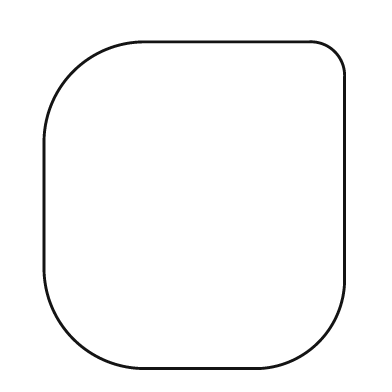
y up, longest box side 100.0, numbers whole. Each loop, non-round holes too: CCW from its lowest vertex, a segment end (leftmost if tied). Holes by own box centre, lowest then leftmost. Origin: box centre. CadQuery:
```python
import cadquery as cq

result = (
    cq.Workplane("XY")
    .moveTo(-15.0, -50.0)
    .lineTo(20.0, -50.0)
    .threePointArc((38.0, -42.0), (46.0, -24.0))
    .lineTo(46.0, 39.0)
    .threePointArc((43.0, 47.0), (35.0, 50.0))
    .lineTo(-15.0, 50.0)
    .threePointArc((-37.0, 41.0), (-46.0, 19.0))
    .lineTo(-46.0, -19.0)
    .threePointArc((-37.0, -41.0), (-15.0, -50.0))
    .close()
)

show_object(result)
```